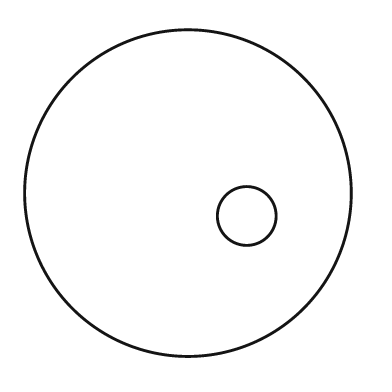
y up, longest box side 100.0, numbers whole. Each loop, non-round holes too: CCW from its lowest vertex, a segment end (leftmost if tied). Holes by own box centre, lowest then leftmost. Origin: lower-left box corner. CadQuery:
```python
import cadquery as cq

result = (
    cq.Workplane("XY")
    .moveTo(50.0, 50.0)
    .circle(50.0)
    .moveTo(68.0, 43.0)
    .circle(9.0)
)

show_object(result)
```